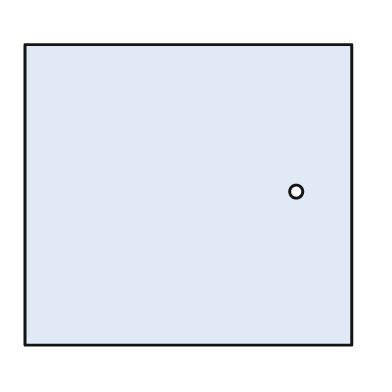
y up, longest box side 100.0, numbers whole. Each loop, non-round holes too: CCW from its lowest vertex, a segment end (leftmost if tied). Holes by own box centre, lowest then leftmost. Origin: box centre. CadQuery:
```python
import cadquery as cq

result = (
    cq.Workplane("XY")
    .moveTo(-50.0, -46.0)
    .lineTo(50.0, -46.0)
    .lineTo(50.0, 46.0)
    .lineTo(-50.0, 46.0)
    .close()
    .moveTo(33.0, 1.0)
    .circle(2.0)
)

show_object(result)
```